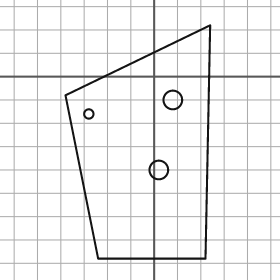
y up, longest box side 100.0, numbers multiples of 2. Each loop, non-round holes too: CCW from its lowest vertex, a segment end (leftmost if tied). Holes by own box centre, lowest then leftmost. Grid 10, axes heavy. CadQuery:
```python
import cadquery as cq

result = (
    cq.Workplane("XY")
    .moveTo(-24.0, -78.0)
    .lineTo(22.0, -78.0)
    .lineTo(24.0, 22.0)
    .lineTo(-38.0, -8.0)
    .close()
    .moveTo(2.0, -40.0)
    .circle(4.0)
    .moveTo(-28.0, -16.0)
    .circle(2.0)
    .moveTo(8.0, -10.0)
    .circle(4.0)
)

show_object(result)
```